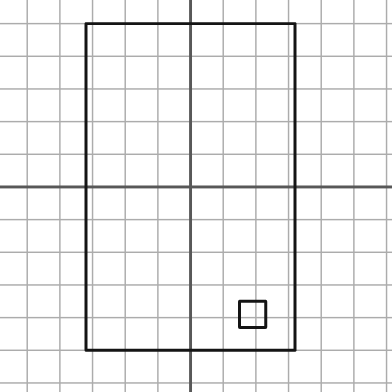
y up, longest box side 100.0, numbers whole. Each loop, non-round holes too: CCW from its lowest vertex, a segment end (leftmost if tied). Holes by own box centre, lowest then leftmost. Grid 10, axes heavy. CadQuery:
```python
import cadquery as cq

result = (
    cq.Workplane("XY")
    .moveTo(-32.0, -50.0)
    .lineTo(32.0, -50.0)
    .lineTo(32.0, 50.0)
    .lineTo(-32.0, 50.0)
    .close()
    .moveTo(15.0, -43.0)
    .lineTo(23.0, -43.0)
    .lineTo(23.0, -35.0)
    .lineTo(15.0, -35.0)
    .close()
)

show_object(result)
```